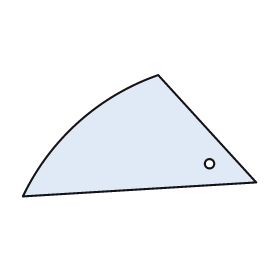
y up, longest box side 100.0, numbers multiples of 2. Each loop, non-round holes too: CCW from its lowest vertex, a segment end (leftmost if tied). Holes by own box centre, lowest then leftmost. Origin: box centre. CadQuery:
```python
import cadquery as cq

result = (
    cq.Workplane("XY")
    .moveTo(-50.0, -26.0)
    .lineTo(50.0, -20.0)
    .lineTo(8.0, 26.0)
    .threePointArc((-26.0, 6.0), (-50.0, -26.0))
    .close()
    .moveTo(30.0, -12.0)
    .circle(2.0)
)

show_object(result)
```